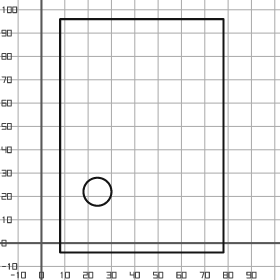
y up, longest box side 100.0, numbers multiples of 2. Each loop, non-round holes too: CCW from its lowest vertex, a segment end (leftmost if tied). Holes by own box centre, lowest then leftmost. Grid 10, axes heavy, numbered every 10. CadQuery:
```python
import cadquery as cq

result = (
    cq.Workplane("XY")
    .moveTo(8.0, -4.0)
    .lineTo(78.0, -4.0)
    .lineTo(78.0, 96.0)
    .lineTo(8.0, 96.0)
    .close()
    .moveTo(24.0, 22.0)
    .circle(6.0)
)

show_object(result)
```